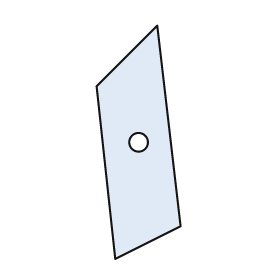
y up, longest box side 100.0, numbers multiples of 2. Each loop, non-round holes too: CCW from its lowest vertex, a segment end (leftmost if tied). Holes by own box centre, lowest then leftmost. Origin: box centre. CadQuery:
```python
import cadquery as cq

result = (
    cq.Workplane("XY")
    .moveTo(-10.0, -50.0)
    .lineTo(18.0, -36.0)
    .lineTo(8.0, 50.0)
    .lineTo(-18.0, 24.0)
    .close()
    .moveTo(0.0, 0.0)
    .circle(4.0)
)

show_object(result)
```